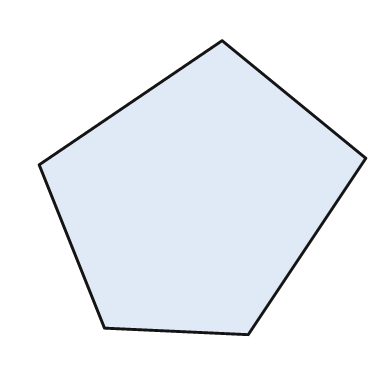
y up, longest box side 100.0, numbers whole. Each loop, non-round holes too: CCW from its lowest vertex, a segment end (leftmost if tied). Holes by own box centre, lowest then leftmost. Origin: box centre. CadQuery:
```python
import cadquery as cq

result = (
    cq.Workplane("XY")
    .moveTo(14.0, -45.0)
    .lineTo(50.0, 9.0)
    .lineTo(6.0, 45.0)
    .lineTo(-50.0, 7.0)
    .lineTo(-30.0, -43.0)
    .close()
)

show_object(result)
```